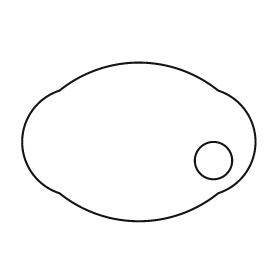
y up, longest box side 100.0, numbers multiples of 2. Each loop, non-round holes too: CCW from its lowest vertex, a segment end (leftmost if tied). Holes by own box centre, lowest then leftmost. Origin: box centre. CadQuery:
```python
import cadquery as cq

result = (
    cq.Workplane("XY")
    .moveTo(-34.0, -22.0)
    .threePointArc((0.0, -34.0), (34.0, -22.0))
    .threePointArc((50.0, 0.0), (34.0, 22.0))
    .threePointArc((0.0, 34.0), (-34.0, 22.0))
    .threePointArc((-50.0, 0.0), (-34.0, -22.0))
    .close()
    .moveTo(32.0, -8.0)
    .circle(8.0)
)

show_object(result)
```